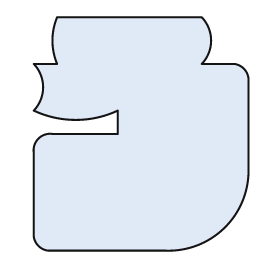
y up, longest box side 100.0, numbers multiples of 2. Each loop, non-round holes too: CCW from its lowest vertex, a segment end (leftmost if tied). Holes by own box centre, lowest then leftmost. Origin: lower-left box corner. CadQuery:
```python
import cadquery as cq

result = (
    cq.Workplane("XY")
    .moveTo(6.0, 0.0)
    .lineTo(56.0, 0.0)
    .threePointArc((82.0, 10.0), (92.0, 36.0))
    .lineTo(92.0, 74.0)
    .threePointArc((90.0, 78.0), (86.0, 80.0))
    .lineTo(72.0, 80.0)
    .threePointArc((76.0, 90.0), (72.0, 100.0))
    .lineTo(10.0, 100.0)
    .threePointArc((8.0, 90.0), (10.0, 80.0))
    .lineTo(0.0, 80.0)
    .threePointArc((4.0, 70.0), (0.0, 60.0))
    .threePointArc((18.0, 56.0), (36.0, 60.0))
    .lineTo(36.0, 50.0)
    .lineTo(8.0, 50.0)
    .threePointArc((2.0, 48.0), (0.0, 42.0))
    .lineTo(0.0, 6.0)
    .threePointArc((2.0, 2.0), (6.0, 0.0))
    .close()
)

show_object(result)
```